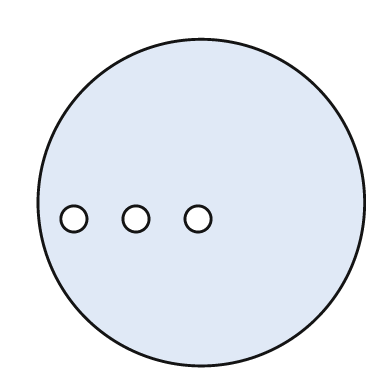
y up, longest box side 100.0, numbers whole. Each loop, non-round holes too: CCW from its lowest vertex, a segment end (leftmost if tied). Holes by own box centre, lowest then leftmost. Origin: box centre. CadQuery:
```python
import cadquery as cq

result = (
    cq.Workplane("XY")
    .moveTo(0.0, 0.0)
    .circle(50.0)
    .moveTo(-39.0, -5.0)
    .circle(4.0)
    .moveTo(-20.0, -5.0)
    .circle(4.0)
    .moveTo(-1.0, -5.0)
    .circle(4.0)
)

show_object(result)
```